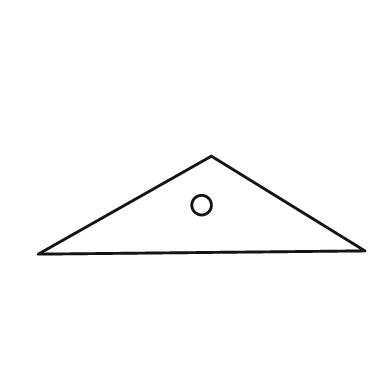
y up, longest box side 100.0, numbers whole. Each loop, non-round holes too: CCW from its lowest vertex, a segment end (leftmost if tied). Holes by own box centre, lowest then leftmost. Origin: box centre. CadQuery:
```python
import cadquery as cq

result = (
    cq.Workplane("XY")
    .moveTo(-50.0, -15.0)
    .lineTo(50.0, -14.0)
    .lineTo(3.0, 15.0)
    .close()
    .moveTo(0.0, 0.0)
    .circle(3.0)
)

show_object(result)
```